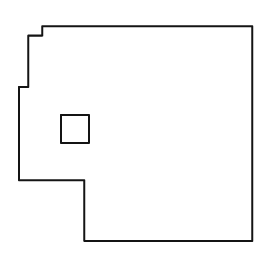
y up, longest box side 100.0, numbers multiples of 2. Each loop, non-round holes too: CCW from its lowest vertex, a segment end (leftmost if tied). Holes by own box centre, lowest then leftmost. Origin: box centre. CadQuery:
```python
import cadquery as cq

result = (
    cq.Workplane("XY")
    .moveTo(-22.0, -46.0)
    .lineTo(50.0, -46.0)
    .lineTo(50.0, 46.0)
    .lineTo(-40.0, 46.0)
    .lineTo(-40.0, 42.0)
    .lineTo(-46.0, 42.0)
    .lineTo(-46.0, 20.0)
    .lineTo(-50.0, 20.0)
    .lineTo(-50.0, -20.0)
    .lineTo(-22.0, -20.0)
    .close()
    .moveTo(-32.0, -4.0)
    .lineTo(-20.0, -4.0)
    .lineTo(-20.0, 8.0)
    .lineTo(-32.0, 8.0)
    .close()
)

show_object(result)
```